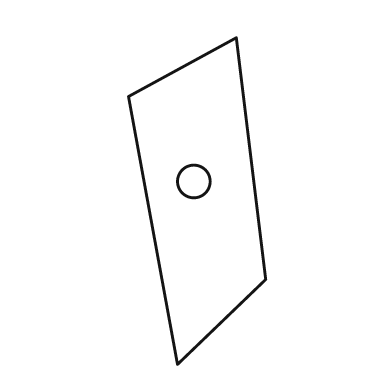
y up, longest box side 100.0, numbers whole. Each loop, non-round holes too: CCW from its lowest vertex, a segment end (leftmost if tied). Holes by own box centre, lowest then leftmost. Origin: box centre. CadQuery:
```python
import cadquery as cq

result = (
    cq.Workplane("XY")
    .moveTo(-6.0, -50.0)
    .lineTo(21.0, -24.0)
    .lineTo(12.0, 50.0)
    .lineTo(-21.0, 32.0)
    .close()
    .moveTo(-1.0, 6.0)
    .circle(5.0)
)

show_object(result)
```